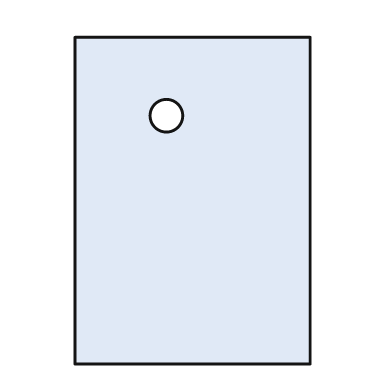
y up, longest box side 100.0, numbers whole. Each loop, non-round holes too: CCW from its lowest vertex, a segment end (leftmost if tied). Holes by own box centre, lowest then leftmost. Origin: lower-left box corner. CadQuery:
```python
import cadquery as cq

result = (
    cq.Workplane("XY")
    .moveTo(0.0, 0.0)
    .lineTo(72.0, 0.0)
    .lineTo(72.0, 100.0)
    .lineTo(0.0, 100.0)
    .close()
    .moveTo(28.0, 76.0)
    .circle(5.0)
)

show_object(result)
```